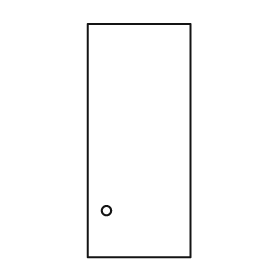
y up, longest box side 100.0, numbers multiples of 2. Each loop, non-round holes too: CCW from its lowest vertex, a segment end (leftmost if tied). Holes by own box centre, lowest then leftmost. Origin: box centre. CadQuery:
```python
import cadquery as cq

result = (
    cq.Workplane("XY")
    .moveTo(-22.0, -50.0)
    .lineTo(22.0, -50.0)
    .lineTo(22.0, 50.0)
    .lineTo(-22.0, 50.0)
    .close()
    .moveTo(-14.0, -30.0)
    .circle(2.0)
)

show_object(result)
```